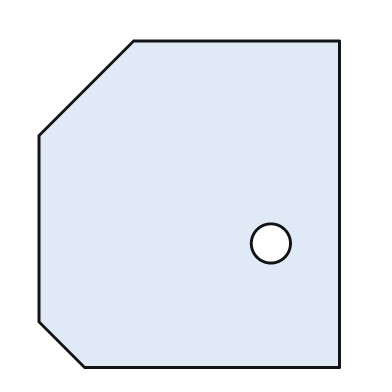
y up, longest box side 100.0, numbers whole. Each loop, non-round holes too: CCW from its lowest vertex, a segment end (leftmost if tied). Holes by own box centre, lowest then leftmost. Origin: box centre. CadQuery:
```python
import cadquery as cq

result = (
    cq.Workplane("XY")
    .moveTo(-32.0, -50.0)
    .lineTo(46.0, -50.0)
    .lineTo(46.0, 50.0)
    .lineTo(-17.0, 50.0)
    .lineTo(-46.0, 21.0)
    .lineTo(-46.0, -36.0)
    .close()
    .moveTo(25.0, -12.0)
    .circle(6.0)
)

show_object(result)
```